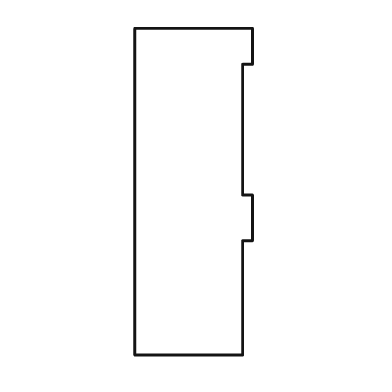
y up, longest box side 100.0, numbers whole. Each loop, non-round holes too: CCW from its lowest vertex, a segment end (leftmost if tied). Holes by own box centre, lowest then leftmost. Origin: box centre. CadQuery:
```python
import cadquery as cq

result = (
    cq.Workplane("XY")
    .moveTo(-18.0, -50.0)
    .lineTo(15.0, -50.0)
    .lineTo(15.0, -15.0)
    .lineTo(18.0, -15.0)
    .lineTo(18.0, -1.0)
    .lineTo(15.0, -1.0)
    .lineTo(15.0, 39.0)
    .lineTo(18.0, 39.0)
    .lineTo(18.0, 50.0)
    .lineTo(-18.0, 50.0)
    .close()
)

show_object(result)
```